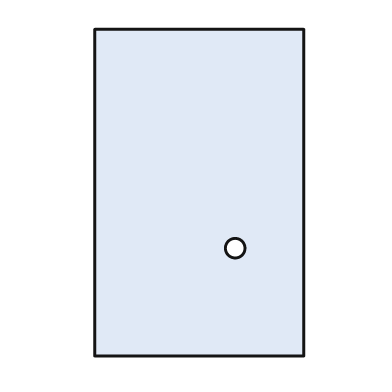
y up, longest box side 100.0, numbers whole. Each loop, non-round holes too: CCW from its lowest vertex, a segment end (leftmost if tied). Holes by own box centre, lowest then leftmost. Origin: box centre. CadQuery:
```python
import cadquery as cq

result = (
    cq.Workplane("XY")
    .moveTo(-32.0, -50.0)
    .lineTo(32.0, -50.0)
    .lineTo(32.0, 50.0)
    .lineTo(-32.0, 50.0)
    .close()
    .moveTo(11.0, -17.0)
    .circle(3.0)
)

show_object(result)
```